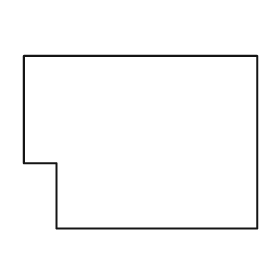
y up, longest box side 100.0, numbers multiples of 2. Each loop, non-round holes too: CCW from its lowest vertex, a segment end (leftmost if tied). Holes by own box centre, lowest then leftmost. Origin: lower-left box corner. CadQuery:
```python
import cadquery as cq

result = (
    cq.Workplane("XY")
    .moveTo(14.0, 0.0)
    .lineTo(100.0, 0.0)
    .lineTo(100.0, 74.0)
    .lineTo(0.0, 74.0)
    .lineTo(0.0, 28.0)
    .lineTo(14.0, 28.0)
    .close()
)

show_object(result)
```